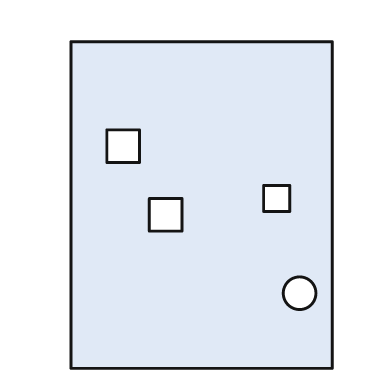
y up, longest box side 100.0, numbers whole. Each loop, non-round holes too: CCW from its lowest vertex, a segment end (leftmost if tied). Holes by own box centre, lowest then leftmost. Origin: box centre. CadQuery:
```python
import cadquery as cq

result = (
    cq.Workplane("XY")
    .moveTo(-40.0, -50.0)
    .lineTo(40.0, -50.0)
    .lineTo(40.0, 50.0)
    .lineTo(-40.0, 50.0)
    .close()
    .moveTo(30.0, -27.0)
    .circle(5.0)
    .moveTo(-16.0, -8.0)
    .lineTo(-6.0, -8.0)
    .lineTo(-6.0, 2.0)
    .lineTo(-16.0, 2.0)
    .close()
    .moveTo(19.0, -2.0)
    .lineTo(27.0, -2.0)
    .lineTo(27.0, 6.0)
    .lineTo(19.0, 6.0)
    .close()
    .moveTo(-29.0, 13.0)
    .lineTo(-19.0, 13.0)
    .lineTo(-19.0, 23.0)
    .lineTo(-29.0, 23.0)
    .close()
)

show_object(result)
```